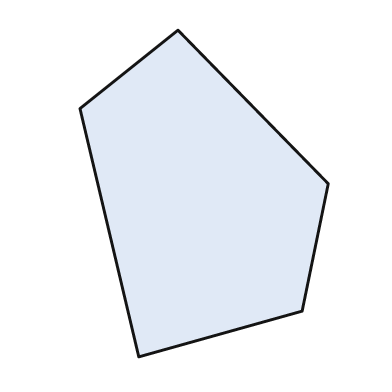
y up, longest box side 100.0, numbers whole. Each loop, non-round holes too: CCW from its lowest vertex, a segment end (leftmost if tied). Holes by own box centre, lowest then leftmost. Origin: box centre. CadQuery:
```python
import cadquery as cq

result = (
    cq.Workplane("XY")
    .moveTo(-20.0, -50.0)
    .lineTo(30.0, -36.0)
    .lineTo(38.0, 3.0)
    .lineTo(-8.0, 50.0)
    .lineTo(-38.0, 26.0)
    .close()
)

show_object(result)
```